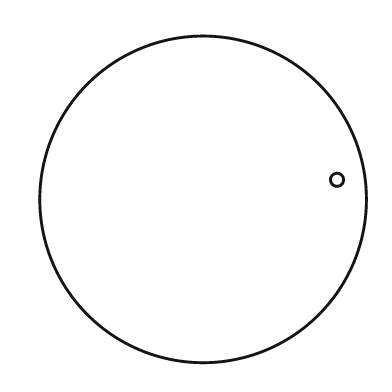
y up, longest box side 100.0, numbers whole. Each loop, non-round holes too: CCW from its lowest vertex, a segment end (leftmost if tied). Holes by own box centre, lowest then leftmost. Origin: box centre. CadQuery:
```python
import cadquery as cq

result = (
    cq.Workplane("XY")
    .moveTo(0.0, 0.0)
    .circle(50.0)
    .moveTo(41.0, 6.0)
    .circle(2.0)
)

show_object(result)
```